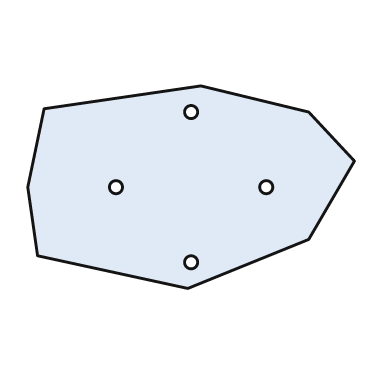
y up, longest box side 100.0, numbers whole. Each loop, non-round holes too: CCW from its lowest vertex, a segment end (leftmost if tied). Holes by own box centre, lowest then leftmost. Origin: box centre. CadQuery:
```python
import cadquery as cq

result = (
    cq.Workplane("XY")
    .moveTo(-1.0, -31.0)
    .lineTo(36.0, -16.0)
    .lineTo(50.0, 8.0)
    .lineTo(36.0, 23.0)
    .lineTo(3.0, 31.0)
    .lineTo(-45.0, 24.0)
    .lineTo(-50.0, 0.0)
    .lineTo(-47.0, -21.0)
    .close()
    .moveTo(0.0, -23.0)
    .circle(2.0)
    .moveTo(-23.0, 0.0)
    .circle(2.0)
    .moveTo(23.0, 0.0)
    .circle(2.0)
    .moveTo(0.0, 23.0)
    .circle(2.0)
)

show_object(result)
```